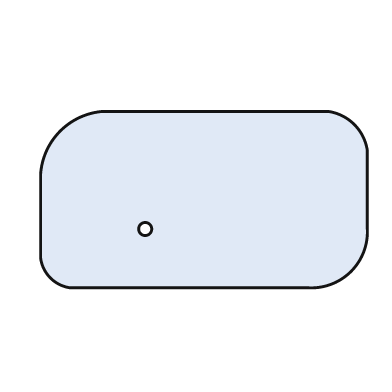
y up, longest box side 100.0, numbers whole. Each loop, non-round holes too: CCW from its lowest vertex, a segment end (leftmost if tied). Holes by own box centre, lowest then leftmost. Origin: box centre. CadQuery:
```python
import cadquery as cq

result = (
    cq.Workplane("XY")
    .moveTo(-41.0, -27.0)
    .lineTo(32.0, -27.0)
    .threePointArc((45.0, -22.0), (50.0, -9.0))
    .lineTo(50.0, 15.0)
    .threePointArc((46.0, 23.0), (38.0, 27.0))
    .lineTo(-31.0, 27.0)
    .threePointArc((-44.0, 21.0), (-50.0, 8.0))
    .lineTo(-50.0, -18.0)
    .threePointArc((-47.0, -24.0), (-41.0, -27.0))
    .close()
    .moveTo(-18.0, -9.0)
    .circle(2.0)
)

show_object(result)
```